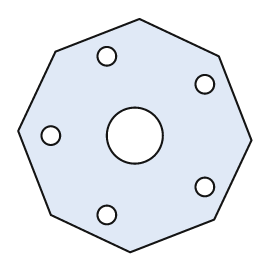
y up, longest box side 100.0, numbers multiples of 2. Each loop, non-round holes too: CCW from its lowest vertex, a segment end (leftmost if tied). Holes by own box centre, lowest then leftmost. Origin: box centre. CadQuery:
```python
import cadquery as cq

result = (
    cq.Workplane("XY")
    .moveTo(-2.0, -50.0)
    .lineTo(34.0, -36.0)
    .lineTo(50.0, -2.0)
    .lineTo(36.0, 34.0)
    .lineTo(2.0, 50.0)
    .lineTo(-34.0, 36.0)
    .lineTo(-50.0, 2.0)
    .lineTo(-36.0, -34.0)
    .close()
    .moveTo(-12.0, -34.0)
    .circle(4.0)
    .moveTo(30.0, -22.0)
    .circle(4.0)
    .moveTo(-36.0, 0.0)
    .circle(4.0)
    .moveTo(0.0, 0.0)
    .circle(12.0)
    .moveTo(30.0, 22.0)
    .circle(4.0)
    .moveTo(-12.0, 34.0)
    .circle(4.0)
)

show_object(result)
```